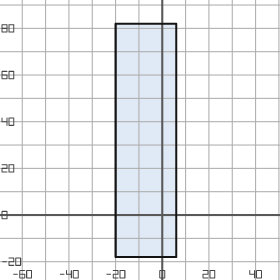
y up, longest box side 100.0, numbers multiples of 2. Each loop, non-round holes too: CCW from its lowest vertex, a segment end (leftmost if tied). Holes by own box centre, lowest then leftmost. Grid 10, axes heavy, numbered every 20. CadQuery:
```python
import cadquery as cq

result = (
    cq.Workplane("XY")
    .moveTo(-20.0, -18.0)
    .lineTo(6.0, -18.0)
    .lineTo(6.0, 82.0)
    .lineTo(-20.0, 82.0)
    .close()
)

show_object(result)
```